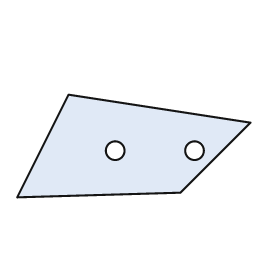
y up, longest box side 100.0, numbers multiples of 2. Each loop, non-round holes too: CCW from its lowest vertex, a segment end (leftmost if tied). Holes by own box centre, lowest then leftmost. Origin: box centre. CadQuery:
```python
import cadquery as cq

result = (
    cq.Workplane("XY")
    .moveTo(-50.0, -22.0)
    .lineTo(20.0, -20.0)
    .lineTo(50.0, 10.0)
    .lineTo(-28.0, 22.0)
    .close()
    .moveTo(-8.0, -2.0)
    .circle(4.0)
    .moveTo(26.0, -2.0)
    .circle(4.0)
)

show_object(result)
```